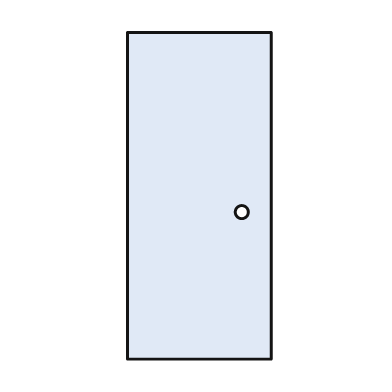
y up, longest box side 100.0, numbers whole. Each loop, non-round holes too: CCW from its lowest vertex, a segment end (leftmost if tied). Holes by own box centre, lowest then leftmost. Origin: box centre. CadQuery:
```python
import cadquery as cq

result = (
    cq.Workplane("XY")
    .moveTo(-22.0, -50.0)
    .lineTo(22.0, -50.0)
    .lineTo(22.0, 50.0)
    .lineTo(-22.0, 50.0)
    .close()
    .moveTo(13.0, -5.0)
    .circle(2.0)
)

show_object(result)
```